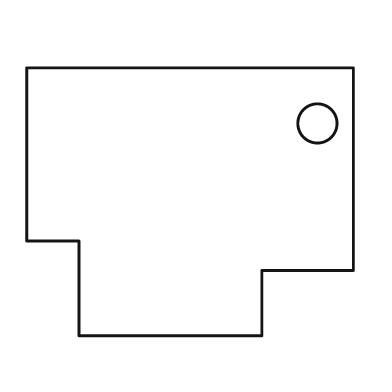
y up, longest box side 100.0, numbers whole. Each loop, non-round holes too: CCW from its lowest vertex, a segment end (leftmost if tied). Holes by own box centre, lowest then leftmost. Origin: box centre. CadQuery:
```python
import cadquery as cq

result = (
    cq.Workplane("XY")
    .moveTo(-34.0, -41.0)
    .lineTo(22.0, -41.0)
    .lineTo(22.0, -21.0)
    .lineTo(50.0, -21.0)
    .lineTo(50.0, 41.0)
    .lineTo(-50.0, 41.0)
    .lineTo(-50.0, -12.0)
    .lineTo(-34.0, -12.0)
    .close()
    .moveTo(39.0, 24.0)
    .circle(6.0)
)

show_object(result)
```